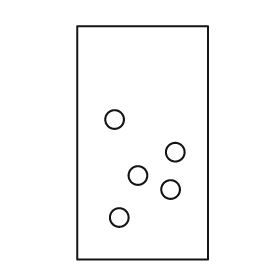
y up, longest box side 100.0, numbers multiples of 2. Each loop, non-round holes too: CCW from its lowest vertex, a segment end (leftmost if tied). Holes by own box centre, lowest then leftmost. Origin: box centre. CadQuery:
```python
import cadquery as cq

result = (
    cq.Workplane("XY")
    .moveTo(-28.0, -50.0)
    .lineTo(28.0, -50.0)
    .lineTo(28.0, 50.0)
    .lineTo(-28.0, 50.0)
    .close()
    .moveTo(-10.0, -32.0)
    .circle(4.0)
    .moveTo(12.0, -20.0)
    .circle(4.0)
    .moveTo(-2.0, -14.0)
    .circle(4.0)
    .moveTo(14.0, -4.0)
    .circle(4.0)
    .moveTo(-12.0, 10.0)
    .circle(4.0)
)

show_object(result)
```